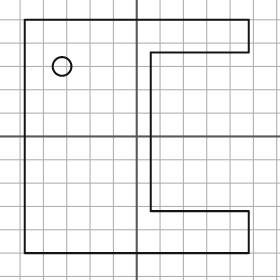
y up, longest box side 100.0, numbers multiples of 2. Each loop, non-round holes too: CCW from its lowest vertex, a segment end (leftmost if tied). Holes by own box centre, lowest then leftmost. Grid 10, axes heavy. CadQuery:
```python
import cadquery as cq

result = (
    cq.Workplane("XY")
    .moveTo(-48.0, -50.0)
    .lineTo(48.0, -50.0)
    .lineTo(48.0, -32.0)
    .lineTo(6.0, -32.0)
    .lineTo(6.0, 36.0)
    .lineTo(48.0, 36.0)
    .lineTo(48.0, 50.0)
    .lineTo(-48.0, 50.0)
    .close()
    .moveTo(-32.0, 30.0)
    .circle(4.0)
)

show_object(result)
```